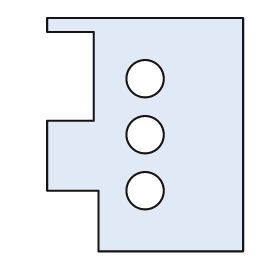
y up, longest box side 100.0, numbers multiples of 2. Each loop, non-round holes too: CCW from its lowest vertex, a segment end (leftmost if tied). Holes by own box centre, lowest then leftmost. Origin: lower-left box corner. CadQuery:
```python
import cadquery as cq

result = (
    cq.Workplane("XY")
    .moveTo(22.0, 0.0)
    .lineTo(84.0, 0.0)
    .lineTo(84.0, 100.0)
    .lineTo(0.0, 100.0)
    .lineTo(0.0, 94.0)
    .lineTo(20.0, 94.0)
    .lineTo(20.0, 56.0)
    .lineTo(0.0, 56.0)
    .lineTo(0.0, 26.0)
    .lineTo(22.0, 26.0)
    .close()
    .moveTo(42.0, 26.0)
    .circle(8.0)
    .moveTo(42.0, 50.0)
    .circle(8.0)
    .moveTo(42.0, 74.0)
    .circle(8.0)
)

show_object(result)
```